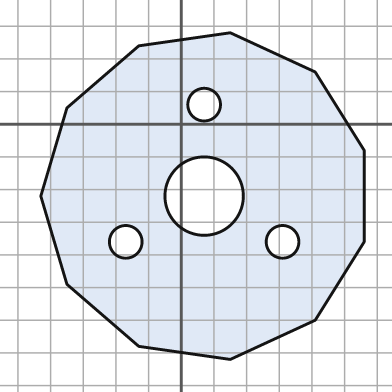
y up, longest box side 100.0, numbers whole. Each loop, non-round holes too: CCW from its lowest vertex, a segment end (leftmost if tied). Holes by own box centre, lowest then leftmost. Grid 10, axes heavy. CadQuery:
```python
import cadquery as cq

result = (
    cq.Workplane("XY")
    .moveTo(15.0, -72.0)
    .lineTo(41.0, -60.0)
    .lineTo(56.0, -36.0)
    .lineTo(56.0, -8.0)
    .lineTo(41.0, 16.0)
    .lineTo(15.0, 28.0)
    .lineTo(-13.0, 24.0)
    .lineTo(-35.0, 5.0)
    .lineTo(-43.0, -22.0)
    .lineTo(-35.0, -49.0)
    .lineTo(-13.0, -68.0)
    .close()
    .moveTo(-17.0, -36.0)
    .circle(5.0)
    .moveTo(31.0, -36.0)
    .circle(5.0)
    .moveTo(7.0, -22.0)
    .circle(12.0)
    .moveTo(7.0, 6.0)
    .circle(5.0)
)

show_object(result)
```